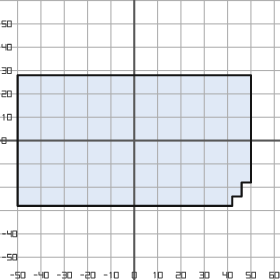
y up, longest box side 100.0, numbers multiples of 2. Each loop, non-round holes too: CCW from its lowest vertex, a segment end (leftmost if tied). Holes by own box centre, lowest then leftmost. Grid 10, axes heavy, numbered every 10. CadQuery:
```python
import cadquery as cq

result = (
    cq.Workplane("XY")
    .moveTo(-50.0, -28.0)
    .lineTo(42.0, -28.0)
    .lineTo(42.0, -24.0)
    .lineTo(46.0, -24.0)
    .lineTo(46.0, -18.0)
    .lineTo(50.0, -18.0)
    .lineTo(50.0, 28.0)
    .lineTo(-50.0, 28.0)
    .close()
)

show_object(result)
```